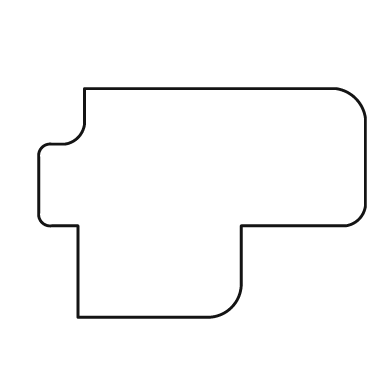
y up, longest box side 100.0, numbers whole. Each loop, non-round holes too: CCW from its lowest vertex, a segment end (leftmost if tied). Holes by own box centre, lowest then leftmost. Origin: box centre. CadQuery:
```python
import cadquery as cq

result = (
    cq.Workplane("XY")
    .moveTo(-38.0, -35.0)
    .lineTo(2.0, -35.0)
    .threePointArc((9.0, -32.0), (12.0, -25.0))
    .lineTo(12.0, -7.0)
    .lineTo(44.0, -7.0)
    .threePointArc((48.0, -5.0), (50.0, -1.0))
    .lineTo(50.0, 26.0)
    .threePointArc((47.0, 32.0), (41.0, 35.0))
    .lineTo(-36.0, 35.0)
    .lineTo(-36.0, 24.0)
    .threePointArc((-38.0, 20.0), (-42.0, 18.0))
    .lineTo(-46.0, 18.0)
    .threePointArc((-49.0, 17.0), (-50.0, 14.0))
    .lineTo(-50.0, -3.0)
    .threePointArc((-49.0, -6.0), (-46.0, -7.0))
    .lineTo(-38.0, -7.0)
    .close()
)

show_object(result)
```